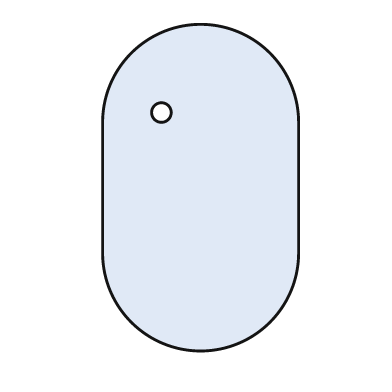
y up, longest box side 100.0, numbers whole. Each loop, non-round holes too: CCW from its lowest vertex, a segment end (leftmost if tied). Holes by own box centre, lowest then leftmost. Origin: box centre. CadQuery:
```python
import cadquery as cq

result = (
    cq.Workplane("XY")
    .moveTo(-30.0, -20.0)
    .threePointArc((0.0, -50.0), (30.0, -20.0))
    .lineTo(30.0, 20.0)
    .threePointArc((0.0, 50.0), (-30.0, 20.0))
    .close()
    .moveTo(-12.0, 23.0)
    .circle(3.0)
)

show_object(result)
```